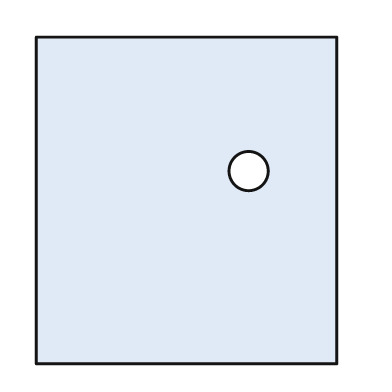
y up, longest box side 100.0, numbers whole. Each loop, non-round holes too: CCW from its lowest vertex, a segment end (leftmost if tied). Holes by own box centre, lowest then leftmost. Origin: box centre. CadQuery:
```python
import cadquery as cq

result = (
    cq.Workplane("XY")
    .moveTo(-46.0, -50.0)
    .lineTo(46.0, -50.0)
    .lineTo(46.0, 50.0)
    .lineTo(-46.0, 50.0)
    .close()
    .moveTo(19.0, 9.0)
    .circle(6.0)
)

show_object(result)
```